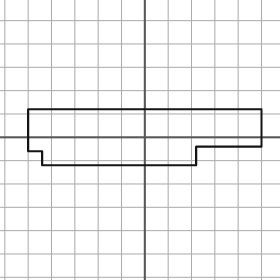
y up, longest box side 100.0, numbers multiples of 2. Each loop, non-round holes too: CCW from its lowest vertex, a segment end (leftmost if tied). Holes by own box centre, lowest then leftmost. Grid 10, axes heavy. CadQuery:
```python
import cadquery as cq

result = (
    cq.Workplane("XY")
    .moveTo(-44.0, -12.0)
    .lineTo(22.0, -12.0)
    .lineTo(22.0, -4.0)
    .lineTo(50.0, -4.0)
    .lineTo(50.0, 12.0)
    .lineTo(-50.0, 12.0)
    .lineTo(-50.0, -6.0)
    .lineTo(-44.0, -6.0)
    .close()
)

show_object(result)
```